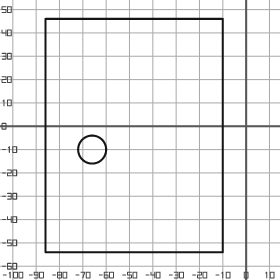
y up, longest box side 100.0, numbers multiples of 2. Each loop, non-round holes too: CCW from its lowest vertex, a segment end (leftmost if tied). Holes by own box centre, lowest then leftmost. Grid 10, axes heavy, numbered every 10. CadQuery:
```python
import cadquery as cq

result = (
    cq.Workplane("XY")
    .moveTo(-86.0, -54.0)
    .lineTo(-10.0, -54.0)
    .lineTo(-10.0, 46.0)
    .lineTo(-86.0, 46.0)
    .close()
    .moveTo(-66.0, -10.0)
    .circle(6.0)
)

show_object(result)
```